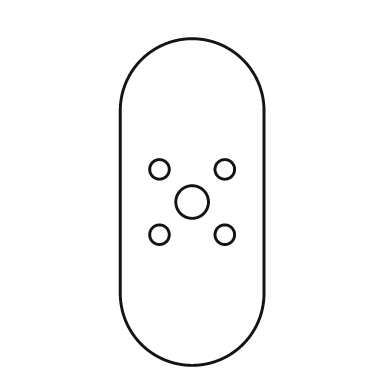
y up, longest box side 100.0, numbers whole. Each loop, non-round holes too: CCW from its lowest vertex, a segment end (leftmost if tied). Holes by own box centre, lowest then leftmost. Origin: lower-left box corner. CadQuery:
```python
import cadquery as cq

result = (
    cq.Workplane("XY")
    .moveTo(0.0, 22.0)
    .threePointArc((22.0, 0.0), (44.0, 22.0))
    .lineTo(44.0, 78.0)
    .threePointArc((22.0, 100.0), (0.0, 78.0))
    .close()
    .moveTo(12.0, 40.0)
    .circle(3.0)
    .moveTo(32.0, 40.0)
    .circle(3.0)
    .moveTo(22.0, 50.0)
    .circle(5.0)
    .moveTo(12.0, 60.0)
    .circle(3.0)
    .moveTo(32.0, 60.0)
    .circle(3.0)
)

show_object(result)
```